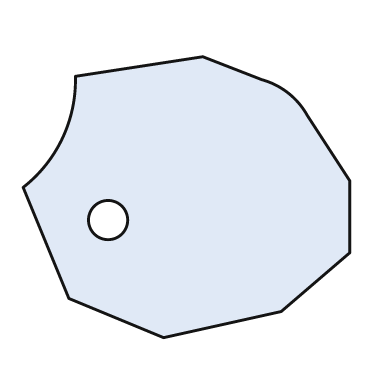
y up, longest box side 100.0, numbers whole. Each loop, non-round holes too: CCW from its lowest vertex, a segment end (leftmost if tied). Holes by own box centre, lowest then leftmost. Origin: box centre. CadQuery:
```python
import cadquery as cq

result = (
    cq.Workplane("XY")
    .moveTo(-7.0, -43.0)
    .lineTo(29.0, -35.0)
    .lineTo(50.0, -17.0)
    .lineTo(50.0, 5.0)
    .lineTo(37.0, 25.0)
    .threePointArc((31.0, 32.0), (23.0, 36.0))
    .lineTo(5.0, 43.0)
    .lineTo(-34.0, 37.0)
    .threePointArc((-38.0, 18.0), (-50.0, 3.0))
    .lineTo(-36.0, -31.0)
    .close()
    .moveTo(-24.0, -7.0)
    .circle(6.0)
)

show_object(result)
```